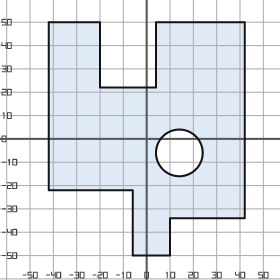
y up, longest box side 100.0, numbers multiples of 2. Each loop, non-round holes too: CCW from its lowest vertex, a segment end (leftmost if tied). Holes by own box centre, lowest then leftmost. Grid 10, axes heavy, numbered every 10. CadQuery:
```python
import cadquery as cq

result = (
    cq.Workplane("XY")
    .moveTo(-6.0, -50.0)
    .lineTo(10.0, -50.0)
    .lineTo(10.0, -34.0)
    .lineTo(42.0, -34.0)
    .lineTo(42.0, 50.0)
    .lineTo(4.0, 50.0)
    .lineTo(4.0, 22.0)
    .lineTo(-20.0, 22.0)
    .lineTo(-20.0, 50.0)
    .lineTo(-42.0, 50.0)
    .lineTo(-42.0, -22.0)
    .lineTo(-6.0, -22.0)
    .close()
    .moveTo(14.0, -6.0)
    .circle(10.0)
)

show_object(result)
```